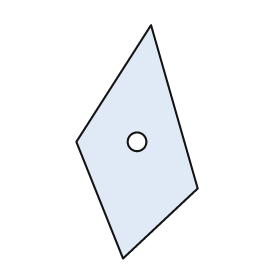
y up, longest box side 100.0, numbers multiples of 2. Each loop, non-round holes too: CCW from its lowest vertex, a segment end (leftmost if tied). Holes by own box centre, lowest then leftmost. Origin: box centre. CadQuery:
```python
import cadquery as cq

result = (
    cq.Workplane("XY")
    .moveTo(-6.0, -50.0)
    .lineTo(26.0, -20.0)
    .lineTo(6.0, 50.0)
    .lineTo(-26.0, 0.0)
    .close()
    .moveTo(0.0, 0.0)
    .circle(4.0)
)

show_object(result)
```